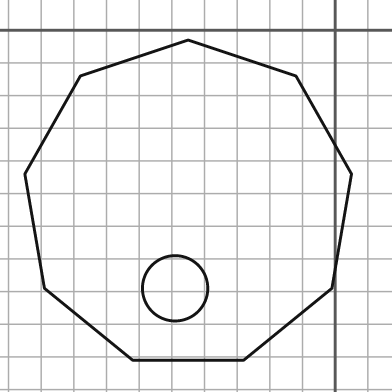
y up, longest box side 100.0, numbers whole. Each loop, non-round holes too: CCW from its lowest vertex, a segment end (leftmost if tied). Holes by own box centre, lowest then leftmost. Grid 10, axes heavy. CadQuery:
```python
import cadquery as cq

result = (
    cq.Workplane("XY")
    .moveTo(-62.0, -101.0)
    .lineTo(-28.0, -101.0)
    .lineTo(-1.0, -79.0)
    .lineTo(5.0, -44.0)
    .lineTo(-12.0, -14.0)
    .lineTo(-45.0, -3.0)
    .lineTo(-78.0, -14.0)
    .lineTo(-95.0, -44.0)
    .lineTo(-89.0, -79.0)
    .close()
    .moveTo(-49.0, -79.0)
    .circle(10.0)
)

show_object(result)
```